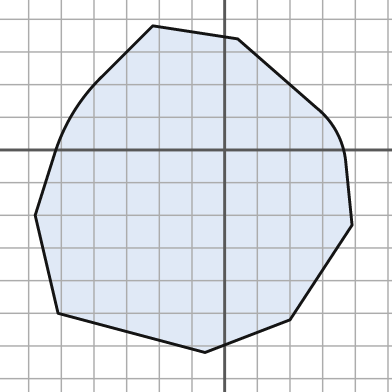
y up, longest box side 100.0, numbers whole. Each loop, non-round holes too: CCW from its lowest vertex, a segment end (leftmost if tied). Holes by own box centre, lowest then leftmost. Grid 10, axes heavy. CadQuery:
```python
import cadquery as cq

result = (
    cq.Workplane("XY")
    .moveTo(-6.0, -62.0)
    .lineTo(20.0, -52.0)
    .lineTo(39.0, -23.0)
    .lineTo(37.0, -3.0)
    .threePointArc((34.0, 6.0), (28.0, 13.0))
    .lineTo(4.0, 34.0)
    .lineTo(-22.0, 38.0)
    .lineTo(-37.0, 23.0)
    .threePointArc((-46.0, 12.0), (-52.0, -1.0))
    .lineTo(-58.0, -20.0)
    .lineTo(-51.0, -50.0)
    .close()
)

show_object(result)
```